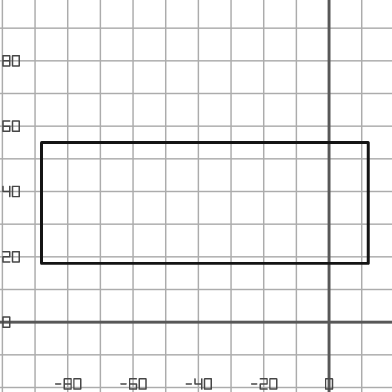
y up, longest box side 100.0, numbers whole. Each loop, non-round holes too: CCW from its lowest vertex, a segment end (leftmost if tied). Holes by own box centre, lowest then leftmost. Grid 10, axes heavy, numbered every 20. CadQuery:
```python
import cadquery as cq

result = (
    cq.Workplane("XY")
    .moveTo(-88.0, 18.0)
    .lineTo(12.0, 18.0)
    .lineTo(12.0, 55.0)
    .lineTo(-88.0, 55.0)
    .close()
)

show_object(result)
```